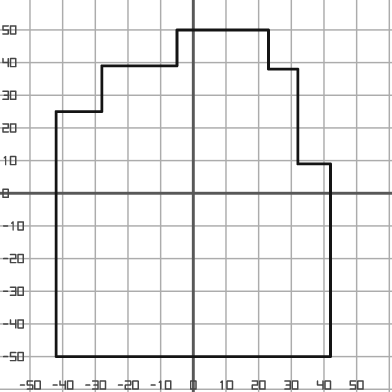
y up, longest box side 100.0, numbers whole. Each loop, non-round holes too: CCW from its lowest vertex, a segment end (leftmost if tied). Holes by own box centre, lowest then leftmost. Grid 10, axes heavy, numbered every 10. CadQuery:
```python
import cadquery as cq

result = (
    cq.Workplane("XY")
    .moveTo(-42.0, -50.0)
    .lineTo(42.0, -50.0)
    .lineTo(42.0, 9.0)
    .lineTo(32.0, 9.0)
    .lineTo(32.0, 38.0)
    .lineTo(23.0, 38.0)
    .lineTo(23.0, 50.0)
    .lineTo(-5.0, 50.0)
    .lineTo(-5.0, 39.0)
    .lineTo(-28.0, 39.0)
    .lineTo(-28.0, 25.0)
    .lineTo(-42.0, 25.0)
    .close()
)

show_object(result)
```